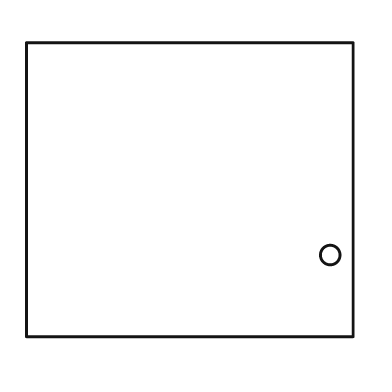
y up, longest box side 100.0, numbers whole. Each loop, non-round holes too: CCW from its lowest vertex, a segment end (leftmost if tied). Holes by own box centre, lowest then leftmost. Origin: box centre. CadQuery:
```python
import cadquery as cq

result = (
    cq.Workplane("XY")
    .moveTo(-50.0, -45.0)
    .lineTo(50.0, -45.0)
    .lineTo(50.0, 45.0)
    .lineTo(-50.0, 45.0)
    .close()
    .moveTo(43.0, -20.0)
    .circle(3.0)
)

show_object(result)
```